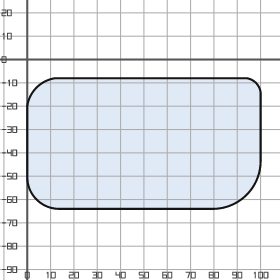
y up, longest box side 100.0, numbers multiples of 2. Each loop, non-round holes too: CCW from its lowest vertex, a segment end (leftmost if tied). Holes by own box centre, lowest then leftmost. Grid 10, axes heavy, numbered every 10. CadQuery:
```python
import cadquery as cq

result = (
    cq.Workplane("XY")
    .moveTo(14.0, -64.0)
    .lineTo(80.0, -64.0)
    .threePointArc((94.0, -58.0), (100.0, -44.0))
    .lineTo(100.0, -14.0)
    .threePointArc((98.0, -10.0), (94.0, -8.0))
    .lineTo(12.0, -8.0)
    .threePointArc((4.0, -12.0), (0.0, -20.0))
    .lineTo(0.0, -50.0)
    .threePointArc((4.0, -60.0), (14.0, -64.0))
    .close()
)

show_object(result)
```